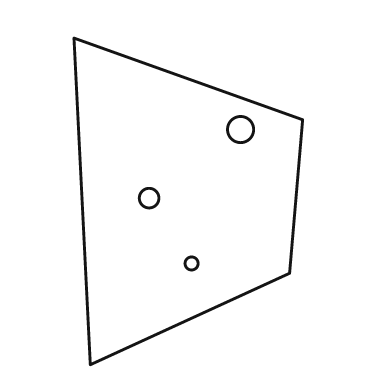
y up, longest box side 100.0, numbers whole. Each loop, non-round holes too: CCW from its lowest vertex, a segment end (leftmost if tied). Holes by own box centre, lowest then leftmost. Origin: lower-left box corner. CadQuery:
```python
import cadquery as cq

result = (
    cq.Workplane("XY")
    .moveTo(5.0, 0.0)
    .lineTo(66.0, 28.0)
    .lineTo(70.0, 75.0)
    .lineTo(0.0, 100.0)
    .close()
    .moveTo(36.0, 31.0)
    .circle(2.0)
    .moveTo(23.0, 51.0)
    .circle(3.0)
    .moveTo(51.0, 72.0)
    .circle(4.0)
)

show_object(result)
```